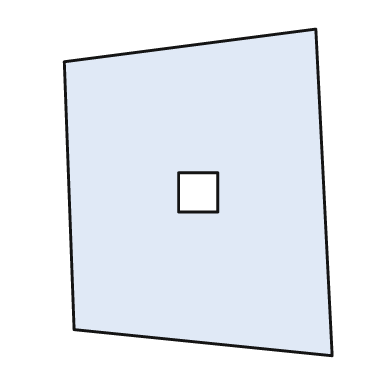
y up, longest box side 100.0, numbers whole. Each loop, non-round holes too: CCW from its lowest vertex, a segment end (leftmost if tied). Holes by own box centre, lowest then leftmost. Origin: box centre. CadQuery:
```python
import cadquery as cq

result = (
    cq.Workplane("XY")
    .moveTo(41.0, -50.0)
    .lineTo(36.0, 50.0)
    .lineTo(-41.0, 40.0)
    .lineTo(-38.0, -42.0)
    .close()
    .moveTo(-6.0, -6.0)
    .lineTo(6.0, -6.0)
    .lineTo(6.0, 6.0)
    .lineTo(-6.0, 6.0)
    .close()
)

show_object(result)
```